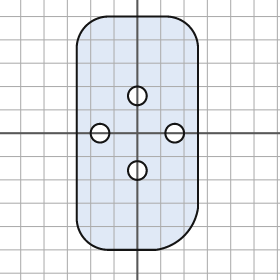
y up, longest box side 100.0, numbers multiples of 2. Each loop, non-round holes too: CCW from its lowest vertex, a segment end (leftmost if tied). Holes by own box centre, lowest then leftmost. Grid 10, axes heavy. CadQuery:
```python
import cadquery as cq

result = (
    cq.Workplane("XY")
    .moveTo(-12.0, -50.0)
    .lineTo(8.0, -50.0)
    .threePointArc((20.0, -44.0), (26.0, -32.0))
    .lineTo(26.0, 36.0)
    .threePointArc((22.0, 46.0), (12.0, 50.0))
    .lineTo(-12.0, 50.0)
    .threePointArc((-22.0, 46.0), (-26.0, 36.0))
    .lineTo(-26.0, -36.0)
    .threePointArc((-22.0, -46.0), (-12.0, -50.0))
    .close()
    .moveTo(0.0, -16.0)
    .circle(4.0)
    .moveTo(-16.0, 0.0)
    .circle(4.0)
    .moveTo(16.0, 0.0)
    .circle(4.0)
    .moveTo(0.0, 16.0)
    .circle(4.0)
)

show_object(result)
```